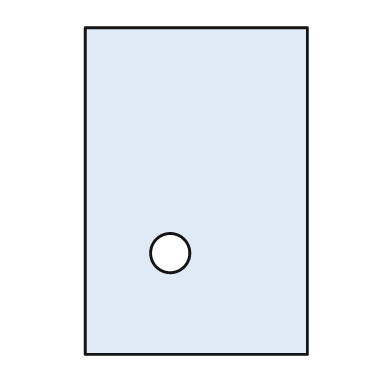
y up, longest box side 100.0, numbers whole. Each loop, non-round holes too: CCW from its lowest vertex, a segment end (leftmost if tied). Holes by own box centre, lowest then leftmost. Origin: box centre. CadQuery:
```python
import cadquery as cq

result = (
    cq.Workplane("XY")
    .moveTo(-34.0, -50.0)
    .lineTo(34.0, -50.0)
    .lineTo(34.0, 50.0)
    .lineTo(-34.0, 50.0)
    .close()
    .moveTo(-8.0, -19.0)
    .circle(6.0)
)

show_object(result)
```